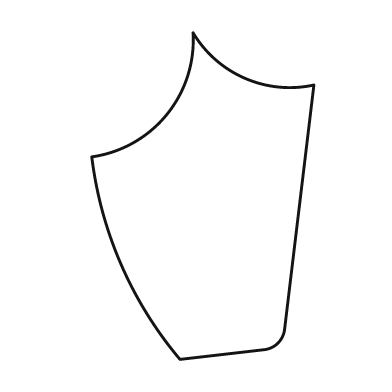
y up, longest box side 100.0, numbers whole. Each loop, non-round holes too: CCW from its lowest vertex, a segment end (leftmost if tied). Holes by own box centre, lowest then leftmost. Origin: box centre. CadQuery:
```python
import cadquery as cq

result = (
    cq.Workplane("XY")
    .moveTo(-7.0, -50.0)
    .lineTo(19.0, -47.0)
    .threePointArc((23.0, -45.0), (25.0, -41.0))
    .lineTo(34.0, 34.0)
    .threePointArc((13.0, 36.0), (-3.0, 50.0))
    .threePointArc((-11.0, 25.0), (-34.0, 12.0))
    .threePointArc((-25.0, -21.0), (-7.0, -50.0))
    .close()
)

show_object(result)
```